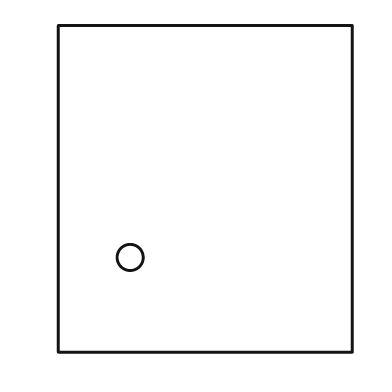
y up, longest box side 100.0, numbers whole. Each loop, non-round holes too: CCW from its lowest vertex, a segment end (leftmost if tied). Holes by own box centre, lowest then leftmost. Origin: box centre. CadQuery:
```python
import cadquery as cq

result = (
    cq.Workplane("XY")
    .moveTo(-45.0, -50.0)
    .lineTo(45.0, -50.0)
    .lineTo(45.0, 50.0)
    .lineTo(-45.0, 50.0)
    .close()
    .moveTo(-23.0, -21.0)
    .circle(4.0)
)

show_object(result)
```